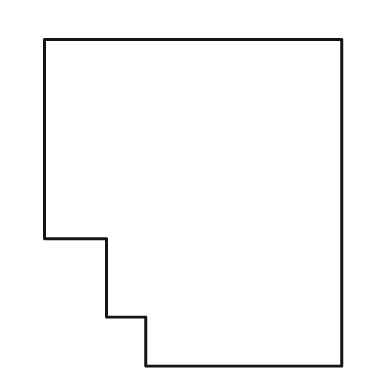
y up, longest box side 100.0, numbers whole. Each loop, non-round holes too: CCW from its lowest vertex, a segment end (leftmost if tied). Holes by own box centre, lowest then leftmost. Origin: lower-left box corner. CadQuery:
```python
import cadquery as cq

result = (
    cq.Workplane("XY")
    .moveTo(31.0, 0.0)
    .lineTo(91.0, 0.0)
    .lineTo(91.0, 100.0)
    .lineTo(0.0, 100.0)
    .lineTo(0.0, 39.0)
    .lineTo(19.0, 39.0)
    .lineTo(19.0, 15.0)
    .lineTo(31.0, 15.0)
    .close()
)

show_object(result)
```